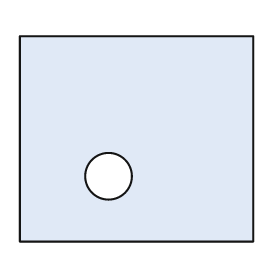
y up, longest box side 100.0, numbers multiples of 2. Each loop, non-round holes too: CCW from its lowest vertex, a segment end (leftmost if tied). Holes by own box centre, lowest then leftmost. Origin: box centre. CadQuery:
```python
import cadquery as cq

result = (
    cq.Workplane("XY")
    .moveTo(-50.0, -44.0)
    .lineTo(50.0, -44.0)
    .lineTo(50.0, 44.0)
    .lineTo(-50.0, 44.0)
    .close()
    .moveTo(-12.0, -16.0)
    .circle(10.0)
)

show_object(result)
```